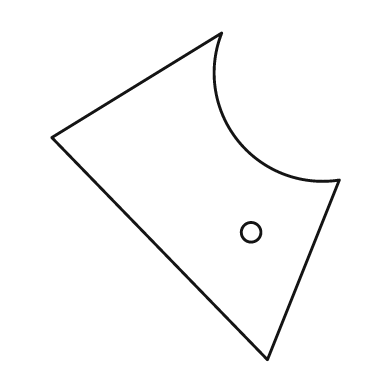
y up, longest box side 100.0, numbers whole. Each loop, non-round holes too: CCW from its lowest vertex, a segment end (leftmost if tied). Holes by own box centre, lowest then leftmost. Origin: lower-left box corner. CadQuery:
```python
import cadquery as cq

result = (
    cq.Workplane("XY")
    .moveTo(66.0, 0.0)
    .lineTo(88.0, 55.0)
    .threePointArc((57.0, 67.0), (52.0, 100.0))
    .lineTo(0.0, 68.0)
    .close()
    .moveTo(61.0, 39.0)
    .circle(3.0)
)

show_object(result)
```